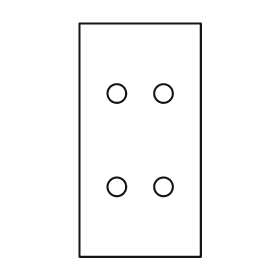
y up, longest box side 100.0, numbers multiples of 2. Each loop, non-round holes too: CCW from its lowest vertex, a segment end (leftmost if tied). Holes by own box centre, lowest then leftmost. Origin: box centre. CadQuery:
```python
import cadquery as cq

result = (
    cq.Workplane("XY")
    .moveTo(-26.0, -50.0)
    .lineTo(26.0, -50.0)
    .lineTo(26.0, 50.0)
    .lineTo(-26.0, 50.0)
    .close()
    .moveTo(-10.0, -20.0)
    .circle(4.0)
    .moveTo(10.0, -20.0)
    .circle(4.0)
    .moveTo(-10.0, 20.0)
    .circle(4.0)
    .moveTo(10.0, 20.0)
    .circle(4.0)
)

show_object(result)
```